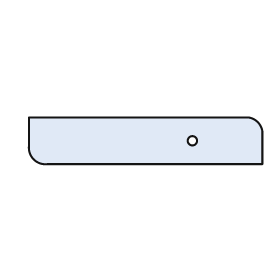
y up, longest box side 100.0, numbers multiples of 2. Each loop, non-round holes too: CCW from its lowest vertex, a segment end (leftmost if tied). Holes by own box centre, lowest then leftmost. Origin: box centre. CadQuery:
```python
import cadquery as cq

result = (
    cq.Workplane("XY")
    .moveTo(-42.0, -10.0)
    .lineTo(50.0, -10.0)
    .lineTo(50.0, 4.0)
    .threePointArc((48.0, 8.0), (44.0, 10.0))
    .lineTo(-50.0, 10.0)
    .lineTo(-50.0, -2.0)
    .threePointArc((-48.0, -8.0), (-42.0, -10.0))
    .close()
    .moveTo(20.0, 0.0)
    .circle(2.0)
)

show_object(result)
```